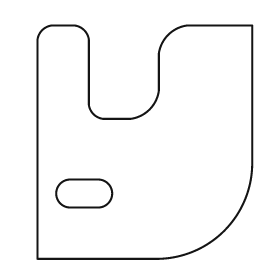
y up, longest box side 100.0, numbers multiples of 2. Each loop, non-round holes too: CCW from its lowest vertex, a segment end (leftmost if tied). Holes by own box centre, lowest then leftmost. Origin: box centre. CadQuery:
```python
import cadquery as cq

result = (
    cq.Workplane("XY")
    .moveTo(-46.0, -50.0)
    .lineTo(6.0, -50.0)
    .threePointArc((34.0, -38.0), (46.0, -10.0))
    .lineTo(46.0, 50.0)
    .lineTo(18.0, 50.0)
    .threePointArc((10.0, 46.0), (6.0, 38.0))
    .lineTo(6.0, 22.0)
    .threePointArc((2.0, 14.0), (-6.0, 10.0))
    .lineTo(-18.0, 10.0)
    .threePointArc((-22.0, 12.0), (-24.0, 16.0))
    .lineTo(-24.0, 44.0)
    .threePointArc((-26.0, 48.0), (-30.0, 50.0))
    .lineTo(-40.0, 50.0)
    .threePointArc((-44.0, 48.0), (-46.0, 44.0))
    .close()
    .moveTo(-32.0, -28.0)
    .lineTo(-20.0, -28.0)
    .threePointArc((-14.0, -22.0), (-20.0, -16.0))
    .lineTo(-32.0, -16.0)
    .threePointArc((-38.0, -22.0), (-32.0, -28.0))
    .close()
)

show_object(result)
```